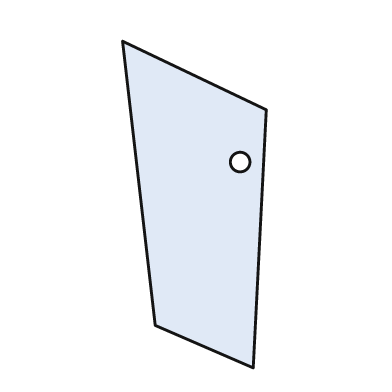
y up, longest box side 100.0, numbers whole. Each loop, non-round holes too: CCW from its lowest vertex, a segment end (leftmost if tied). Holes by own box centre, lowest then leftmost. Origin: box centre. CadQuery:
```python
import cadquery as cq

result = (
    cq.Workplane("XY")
    .moveTo(18.0, -50.0)
    .lineTo(22.0, 29.0)
    .lineTo(-22.0, 50.0)
    .lineTo(-12.0, -37.0)
    .close()
    .moveTo(14.0, 13.0)
    .circle(3.0)
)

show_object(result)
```